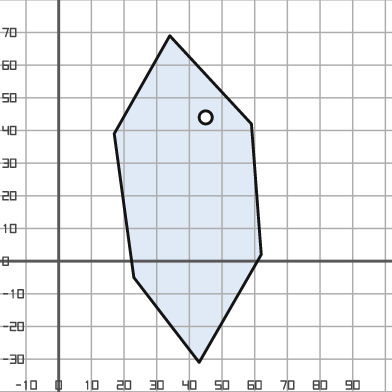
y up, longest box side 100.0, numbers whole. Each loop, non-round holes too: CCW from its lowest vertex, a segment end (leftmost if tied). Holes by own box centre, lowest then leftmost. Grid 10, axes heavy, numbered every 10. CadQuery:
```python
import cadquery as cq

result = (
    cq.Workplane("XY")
    .moveTo(43.0, -31.0)
    .lineTo(62.0, 2.0)
    .lineTo(59.0, 42.0)
    .lineTo(34.0, 69.0)
    .lineTo(17.0, 39.0)
    .lineTo(23.0, -5.0)
    .close()
    .moveTo(45.0, 44.0)
    .circle(2.0)
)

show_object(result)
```